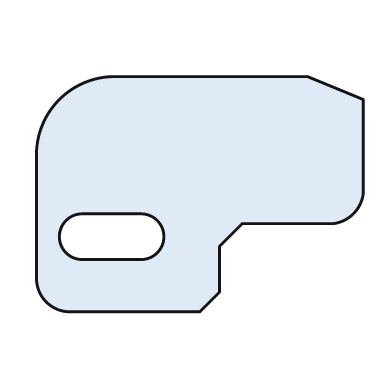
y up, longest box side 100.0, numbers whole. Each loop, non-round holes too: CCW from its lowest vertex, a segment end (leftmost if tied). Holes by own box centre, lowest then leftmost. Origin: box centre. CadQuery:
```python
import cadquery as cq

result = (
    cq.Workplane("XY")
    .moveTo(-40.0, -36.0)
    .lineTo(0.0, -36.0)
    .lineTo(6.0, -30.0)
    .lineTo(6.0, -16.0)
    .lineTo(13.0, -9.0)
    .lineTo(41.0, -9.0)
    .threePointArc((47.0, -6.0), (50.0, 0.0))
    .lineTo(50.0, 29.0)
    .lineTo(33.0, 36.0)
    .lineTo(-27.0, 36.0)
    .threePointArc((-43.0, 29.0), (-50.0, 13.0))
    .lineTo(-50.0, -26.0)
    .threePointArc((-47.0, -33.0), (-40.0, -36.0))
    .close()
    .moveTo(-36.0, -20.0)
    .lineTo(-18.0, -20.0)
    .threePointArc((-11.0, -13.0), (-18.0, -6.0))
    .lineTo(-36.0, -6.0)
    .threePointArc((-43.0, -13.0), (-36.0, -20.0))
    .close()
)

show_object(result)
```